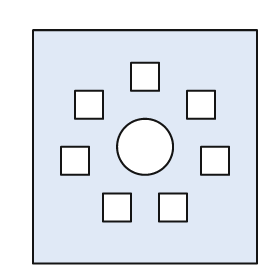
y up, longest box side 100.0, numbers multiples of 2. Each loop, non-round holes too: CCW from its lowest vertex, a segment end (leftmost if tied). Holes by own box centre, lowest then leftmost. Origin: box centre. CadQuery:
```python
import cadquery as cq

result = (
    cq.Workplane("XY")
    .moveTo(-48.0, -50.0)
    .lineTo(48.0, -50.0)
    .lineTo(48.0, 50.0)
    .lineTo(-48.0, 50.0)
    .close()
    .moveTo(-18.0, -32.0)
    .lineTo(-6.0, -32.0)
    .lineTo(-6.0, -20.0)
    .lineTo(-18.0, -20.0)
    .close()
    .moveTo(6.0, -32.0)
    .lineTo(18.0, -32.0)
    .lineTo(18.0, -20.0)
    .lineTo(6.0, -20.0)
    .close()
    .moveTo(-36.0, -12.0)
    .lineTo(-24.0, -12.0)
    .lineTo(-24.0, 0.0)
    .lineTo(-36.0, 0.0)
    .close()
    .moveTo(24.0, -12.0)
    .lineTo(36.0, -12.0)
    .lineTo(36.0, 0.0)
    .lineTo(24.0, 0.0)
    .close()
    .moveTo(0.0, 0.0)
    .circle(12.0)
    .moveTo(-30.0, 12.0)
    .lineTo(-18.0, 12.0)
    .lineTo(-18.0, 24.0)
    .lineTo(-30.0, 24.0)
    .close()
    .moveTo(18.0, 12.0)
    .lineTo(30.0, 12.0)
    .lineTo(30.0, 24.0)
    .lineTo(18.0, 24.0)
    .close()
    .moveTo(-6.0, 24.0)
    .lineTo(6.0, 24.0)
    .lineTo(6.0, 36.0)
    .lineTo(-6.0, 36.0)
    .close()
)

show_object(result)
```